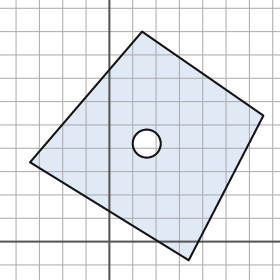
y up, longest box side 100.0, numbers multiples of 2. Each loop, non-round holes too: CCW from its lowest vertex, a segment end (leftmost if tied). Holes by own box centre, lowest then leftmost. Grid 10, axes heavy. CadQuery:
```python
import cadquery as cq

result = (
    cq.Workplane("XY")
    .moveTo(34.0, -8.0)
    .lineTo(66.0, 54.0)
    .lineTo(14.0, 90.0)
    .lineTo(-34.0, 34.0)
    .close()
    .moveTo(16.0, 42.0)
    .circle(6.0)
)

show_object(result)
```